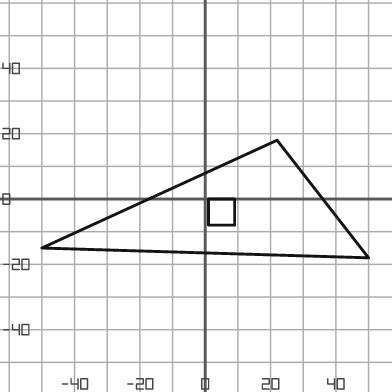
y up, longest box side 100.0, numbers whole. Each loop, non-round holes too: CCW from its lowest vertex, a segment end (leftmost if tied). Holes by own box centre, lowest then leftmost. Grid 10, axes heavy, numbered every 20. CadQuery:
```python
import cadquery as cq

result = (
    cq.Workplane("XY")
    .moveTo(50.0, -18.0)
    .lineTo(22.0, 18.0)
    .lineTo(-50.0, -15.0)
    .close()
    .moveTo(1.0, -8.0)
    .lineTo(9.0, -8.0)
    .lineTo(9.0, 0.0)
    .lineTo(1.0, 0.0)
    .close()
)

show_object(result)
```